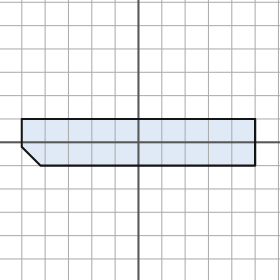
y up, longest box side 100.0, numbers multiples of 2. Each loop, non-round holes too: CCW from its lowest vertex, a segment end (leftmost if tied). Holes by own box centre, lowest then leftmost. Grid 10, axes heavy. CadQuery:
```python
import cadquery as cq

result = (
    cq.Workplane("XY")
    .moveTo(-42.0, -10.0)
    .lineTo(50.0, -10.0)
    .lineTo(50.0, 10.0)
    .lineTo(-50.0, 10.0)
    .lineTo(-50.0, -2.0)
    .close()
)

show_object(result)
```